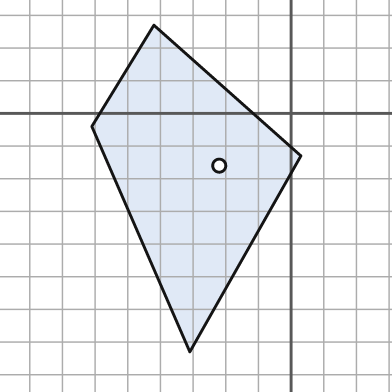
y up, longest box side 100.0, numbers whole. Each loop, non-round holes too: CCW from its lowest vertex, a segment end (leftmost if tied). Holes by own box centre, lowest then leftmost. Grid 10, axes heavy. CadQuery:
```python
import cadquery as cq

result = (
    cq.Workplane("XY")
    .moveTo(-31.0, -73.0)
    .lineTo(3.0, -13.0)
    .lineTo(-42.0, 27.0)
    .lineTo(-61.0, -4.0)
    .close()
    .moveTo(-22.0, -16.0)
    .circle(2.0)
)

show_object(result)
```